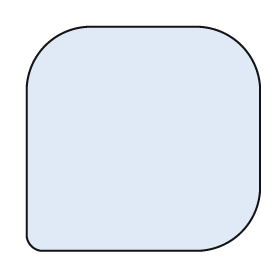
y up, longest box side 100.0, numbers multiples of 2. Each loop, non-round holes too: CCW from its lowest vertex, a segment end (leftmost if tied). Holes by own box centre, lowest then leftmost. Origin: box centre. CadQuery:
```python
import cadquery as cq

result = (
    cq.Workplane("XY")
    .moveTo(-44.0, -48.0)
    .lineTo(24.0, -48.0)
    .threePointArc((42.0, -40.0), (50.0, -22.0))
    .lineTo(50.0, 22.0)
    .threePointArc((42.0, 40.0), (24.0, 48.0))
    .lineTo(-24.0, 48.0)
    .threePointArc((-42.0, 40.0), (-50.0, 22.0))
    .lineTo(-50.0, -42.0)
    .threePointArc((-48.0, -46.0), (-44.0, -48.0))
    .close()
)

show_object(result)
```